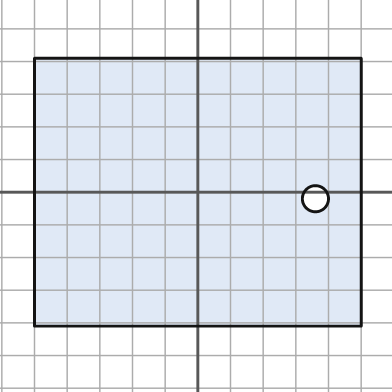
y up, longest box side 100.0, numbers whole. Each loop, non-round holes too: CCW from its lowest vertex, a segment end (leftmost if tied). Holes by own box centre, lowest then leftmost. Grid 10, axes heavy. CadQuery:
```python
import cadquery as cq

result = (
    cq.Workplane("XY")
    .moveTo(-50.0, -41.0)
    .lineTo(50.0, -41.0)
    .lineTo(50.0, 41.0)
    .lineTo(-50.0, 41.0)
    .close()
    .moveTo(36.0, -2.0)
    .circle(4.0)
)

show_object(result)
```